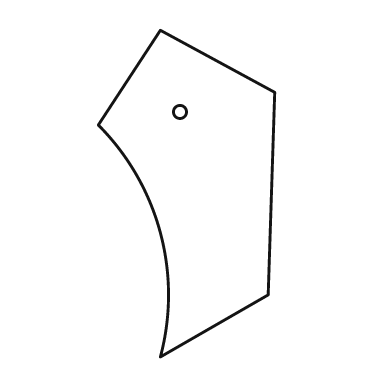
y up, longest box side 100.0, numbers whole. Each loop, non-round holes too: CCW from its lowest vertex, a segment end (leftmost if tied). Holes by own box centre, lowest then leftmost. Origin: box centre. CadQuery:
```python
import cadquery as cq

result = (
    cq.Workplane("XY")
    .moveTo(-8.0, -50.0)
    .lineTo(25.0, -31.0)
    .lineTo(27.0, 31.0)
    .lineTo(-8.0, 50.0)
    .lineTo(-27.0, 21.0)
    .threePointArc((-8.0, -12.0), (-8.0, -50.0))
    .close()
    .moveTo(-2.0, 25.0)
    .circle(2.0)
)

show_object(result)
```